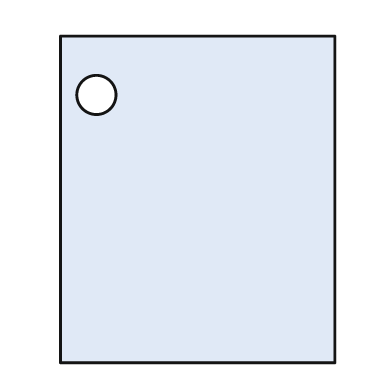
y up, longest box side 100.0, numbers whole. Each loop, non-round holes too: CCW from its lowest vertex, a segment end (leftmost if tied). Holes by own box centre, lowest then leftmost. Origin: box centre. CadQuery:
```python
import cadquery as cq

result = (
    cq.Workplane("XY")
    .moveTo(-42.0, -50.0)
    .lineTo(42.0, -50.0)
    .lineTo(42.0, 50.0)
    .lineTo(-42.0, 50.0)
    .close()
    .moveTo(-31.0, 32.0)
    .circle(6.0)
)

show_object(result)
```